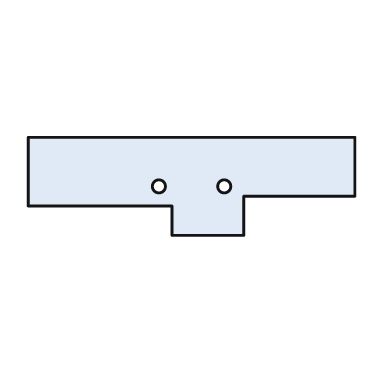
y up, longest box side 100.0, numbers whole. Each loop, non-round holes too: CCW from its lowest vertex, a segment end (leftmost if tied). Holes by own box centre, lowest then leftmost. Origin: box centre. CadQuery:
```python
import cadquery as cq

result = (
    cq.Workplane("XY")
    .moveTo(-6.0, -15.0)
    .lineTo(16.0, -15.0)
    .lineTo(16.0, -3.0)
    .lineTo(50.0, -3.0)
    .lineTo(50.0, 15.0)
    .lineTo(-50.0, 15.0)
    .lineTo(-50.0, -6.0)
    .lineTo(-6.0, -6.0)
    .close()
    .moveTo(-10.0, 0.0)
    .circle(2.0)
    .moveTo(10.0, 0.0)
    .circle(2.0)
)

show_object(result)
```